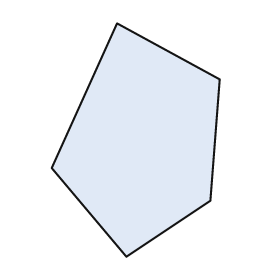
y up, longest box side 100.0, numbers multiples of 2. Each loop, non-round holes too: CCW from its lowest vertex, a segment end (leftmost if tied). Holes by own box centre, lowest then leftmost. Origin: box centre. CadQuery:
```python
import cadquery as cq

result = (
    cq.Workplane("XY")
    .moveTo(-4.0, -50.0)
    .lineTo(32.0, -26.0)
    .lineTo(36.0, 26.0)
    .lineTo(-8.0, 50.0)
    .lineTo(-36.0, -12.0)
    .close()
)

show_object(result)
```